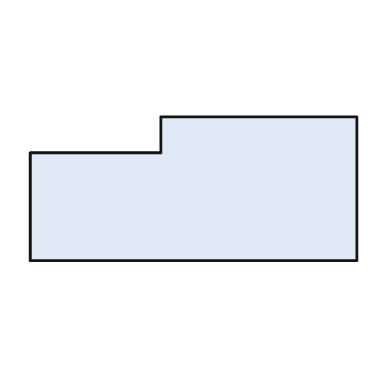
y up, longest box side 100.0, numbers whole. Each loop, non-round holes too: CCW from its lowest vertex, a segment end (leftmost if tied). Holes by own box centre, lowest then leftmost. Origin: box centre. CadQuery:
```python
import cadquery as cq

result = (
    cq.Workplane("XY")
    .moveTo(-50.0, -22.0)
    .lineTo(50.0, -22.0)
    .lineTo(50.0, 22.0)
    .lineTo(-10.0, 22.0)
    .lineTo(-10.0, 11.0)
    .lineTo(-50.0, 11.0)
    .close()
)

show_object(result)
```